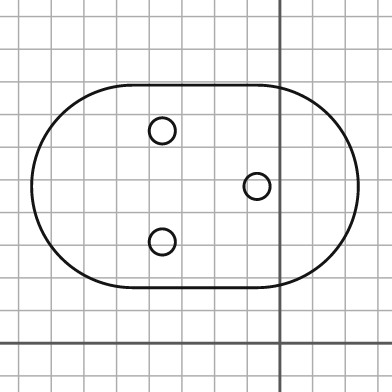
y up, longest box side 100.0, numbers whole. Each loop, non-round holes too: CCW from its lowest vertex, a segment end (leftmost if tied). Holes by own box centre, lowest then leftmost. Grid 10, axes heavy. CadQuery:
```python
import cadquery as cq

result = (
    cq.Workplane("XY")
    .moveTo(-45.0, 17.0)
    .lineTo(-7.0, 17.0)
    .threePointArc((24.0, 48.0), (-7.0, 79.0))
    .lineTo(-45.0, 79.0)
    .threePointArc((-76.0, 48.0), (-45.0, 17.0))
    .close()
    .moveTo(-36.0, 31.0)
    .circle(4.0)
    .moveTo(-7.0, 48.0)
    .circle(4.0)
    .moveTo(-36.0, 65.0)
    .circle(4.0)
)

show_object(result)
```